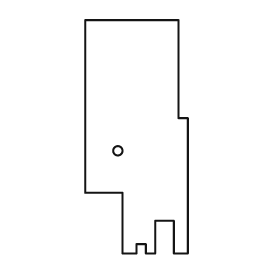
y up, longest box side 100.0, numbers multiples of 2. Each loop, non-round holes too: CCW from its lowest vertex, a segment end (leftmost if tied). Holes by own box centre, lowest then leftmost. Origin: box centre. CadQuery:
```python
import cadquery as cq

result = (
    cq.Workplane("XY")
    .moveTo(-6.0, -50.0)
    .lineTo(0.0, -50.0)
    .lineTo(0.0, -46.0)
    .lineTo(4.0, -46.0)
    .lineTo(4.0, -50.0)
    .lineTo(8.0, -50.0)
    .lineTo(8.0, -36.0)
    .lineTo(16.0, -36.0)
    .lineTo(16.0, -50.0)
    .lineTo(22.0, -50.0)
    .lineTo(22.0, 8.0)
    .lineTo(18.0, 8.0)
    .lineTo(18.0, 50.0)
    .lineTo(-22.0, 50.0)
    .lineTo(-22.0, -24.0)
    .lineTo(-6.0, -24.0)
    .close()
    .moveTo(-8.0, -6.0)
    .circle(2.0)
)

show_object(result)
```